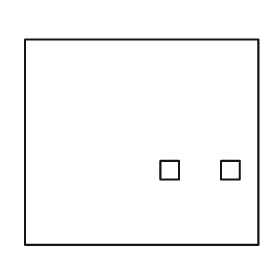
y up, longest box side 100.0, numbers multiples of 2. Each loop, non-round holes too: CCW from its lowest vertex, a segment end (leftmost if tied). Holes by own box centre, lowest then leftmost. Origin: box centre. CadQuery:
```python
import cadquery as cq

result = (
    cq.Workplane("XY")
    .moveTo(-50.0, -44.0)
    .lineTo(50.0, -44.0)
    .lineTo(50.0, 44.0)
    .lineTo(-50.0, 44.0)
    .close()
    .moveTo(8.0, -16.0)
    .lineTo(16.0, -16.0)
    .lineTo(16.0, -8.0)
    .lineTo(8.0, -8.0)
    .close()
    .moveTo(34.0, -16.0)
    .lineTo(42.0, -16.0)
    .lineTo(42.0, -8.0)
    .lineTo(34.0, -8.0)
    .close()
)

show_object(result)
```